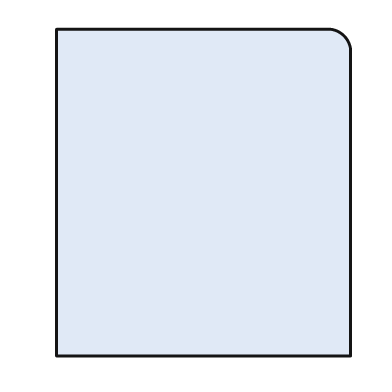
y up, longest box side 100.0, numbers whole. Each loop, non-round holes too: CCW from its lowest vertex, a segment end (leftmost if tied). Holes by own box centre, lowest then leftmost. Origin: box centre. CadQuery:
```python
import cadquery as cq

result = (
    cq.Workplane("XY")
    .moveTo(-45.0, -50.0)
    .lineTo(45.0, -50.0)
    .lineTo(45.0, 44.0)
    .threePointArc((43.0, 48.0), (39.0, 50.0))
    .lineTo(-45.0, 50.0)
    .close()
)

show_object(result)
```